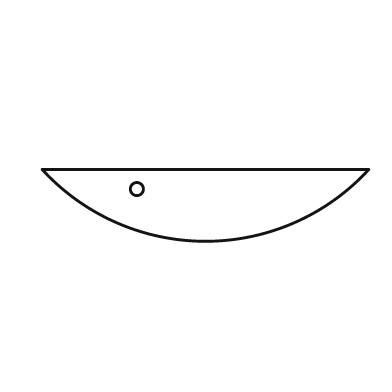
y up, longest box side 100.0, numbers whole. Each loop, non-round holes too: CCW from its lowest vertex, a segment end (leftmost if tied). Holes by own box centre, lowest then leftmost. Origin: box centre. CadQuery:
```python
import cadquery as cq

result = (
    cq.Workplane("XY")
    .moveTo(-50.0, 11.0)
    .threePointArc((0.0, -11.0), (50.0, 11.0))
    .close()
    .moveTo(-21.0, 5.0)
    .circle(2.0)
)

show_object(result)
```